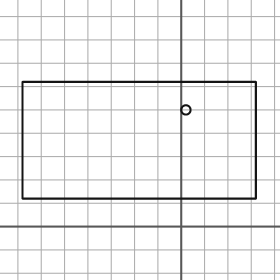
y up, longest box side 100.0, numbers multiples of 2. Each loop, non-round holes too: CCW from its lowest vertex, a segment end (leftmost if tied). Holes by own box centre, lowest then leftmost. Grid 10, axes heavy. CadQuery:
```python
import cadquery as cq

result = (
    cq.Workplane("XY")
    .moveTo(-68.0, 12.0)
    .lineTo(32.0, 12.0)
    .lineTo(32.0, 62.0)
    .lineTo(-68.0, 62.0)
    .close()
    .moveTo(2.0, 50.0)
    .circle(2.0)
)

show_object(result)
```